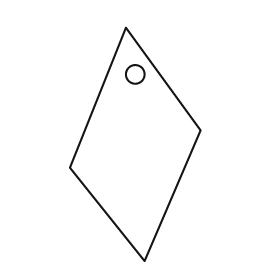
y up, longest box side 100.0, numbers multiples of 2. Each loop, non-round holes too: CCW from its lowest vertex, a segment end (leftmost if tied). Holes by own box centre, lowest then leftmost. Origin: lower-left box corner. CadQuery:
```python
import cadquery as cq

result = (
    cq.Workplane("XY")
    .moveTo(32.0, 0.0)
    .lineTo(56.0, 56.0)
    .lineTo(24.0, 100.0)
    .lineTo(0.0, 40.0)
    .close()
    .moveTo(28.0, 80.0)
    .circle(4.0)
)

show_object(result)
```